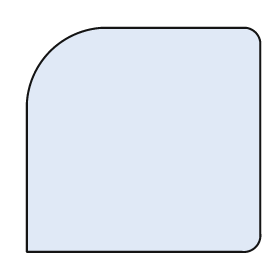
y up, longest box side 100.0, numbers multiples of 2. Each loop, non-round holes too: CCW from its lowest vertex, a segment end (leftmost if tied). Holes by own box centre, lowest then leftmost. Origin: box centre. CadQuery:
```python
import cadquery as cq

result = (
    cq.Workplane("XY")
    .moveTo(-50.0, -48.0)
    .lineTo(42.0, -48.0)
    .threePointArc((48.0, -46.0), (50.0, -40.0))
    .lineTo(50.0, 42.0)
    .threePointArc((48.0, 46.0), (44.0, 48.0))
    .lineTo(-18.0, 48.0)
    .threePointArc((-40.0, 38.0), (-50.0, 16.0))
    .close()
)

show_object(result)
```